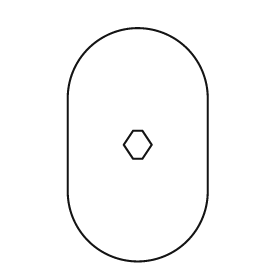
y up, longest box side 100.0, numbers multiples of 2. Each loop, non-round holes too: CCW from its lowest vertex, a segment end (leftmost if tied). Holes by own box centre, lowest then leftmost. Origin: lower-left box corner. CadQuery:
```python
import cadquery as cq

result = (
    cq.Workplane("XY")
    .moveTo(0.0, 30.0)
    .threePointArc((30.0, 0.0), (60.0, 30.0))
    .lineTo(60.0, 70.0)
    .threePointArc((30.0, 100.0), (0.0, 70.0))
    .close()
    .moveTo(28.0, 44.0)
    .lineTo(32.0, 44.0)
    .lineTo(36.0, 50.0)
    .lineTo(32.0, 56.0)
    .lineTo(28.0, 56.0)
    .lineTo(24.0, 50.0)
    .close()
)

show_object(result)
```